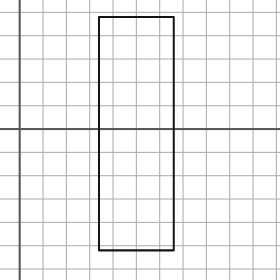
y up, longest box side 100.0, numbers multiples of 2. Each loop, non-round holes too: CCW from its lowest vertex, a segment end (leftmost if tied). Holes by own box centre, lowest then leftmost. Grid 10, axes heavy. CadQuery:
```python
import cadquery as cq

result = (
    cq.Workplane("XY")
    .moveTo(34.0, -52.0)
    .lineTo(66.0, -52.0)
    .lineTo(66.0, 48.0)
    .lineTo(34.0, 48.0)
    .close()
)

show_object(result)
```